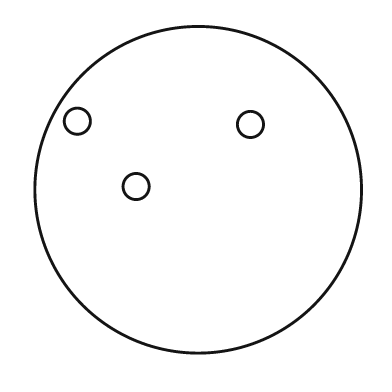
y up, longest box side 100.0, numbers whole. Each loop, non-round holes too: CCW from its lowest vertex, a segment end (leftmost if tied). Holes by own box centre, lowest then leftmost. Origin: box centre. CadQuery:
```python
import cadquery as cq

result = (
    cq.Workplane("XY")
    .moveTo(0.0, 0.0)
    .circle(50.0)
    .moveTo(-19.0, 1.0)
    .circle(4.0)
    .moveTo(16.0, 20.0)
    .circle(4.0)
    .moveTo(-37.0, 21.0)
    .circle(4.0)
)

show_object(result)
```